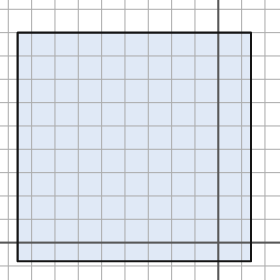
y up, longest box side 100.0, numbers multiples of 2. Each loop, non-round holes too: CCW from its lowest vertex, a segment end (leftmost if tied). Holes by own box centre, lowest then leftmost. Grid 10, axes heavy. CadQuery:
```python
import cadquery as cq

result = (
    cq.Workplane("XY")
    .moveTo(-86.0, -8.0)
    .lineTo(14.0, -8.0)
    .lineTo(14.0, 90.0)
    .lineTo(-86.0, 90.0)
    .close()
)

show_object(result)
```